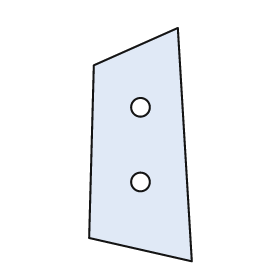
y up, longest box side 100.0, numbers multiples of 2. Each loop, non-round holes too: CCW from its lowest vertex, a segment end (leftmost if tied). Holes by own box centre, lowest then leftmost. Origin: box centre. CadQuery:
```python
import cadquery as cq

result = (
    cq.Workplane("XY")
    .moveTo(22.0, -50.0)
    .lineTo(16.0, 50.0)
    .lineTo(-20.0, 34.0)
    .lineTo(-22.0, -40.0)
    .close()
    .moveTo(0.0, -16.0)
    .circle(4.0)
    .moveTo(0.0, 16.0)
    .circle(4.0)
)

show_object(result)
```